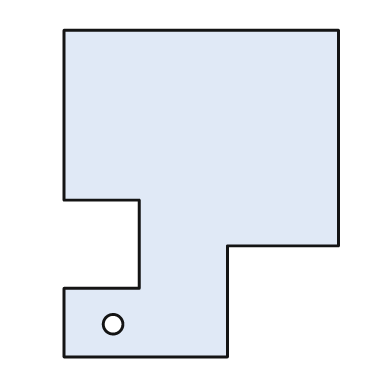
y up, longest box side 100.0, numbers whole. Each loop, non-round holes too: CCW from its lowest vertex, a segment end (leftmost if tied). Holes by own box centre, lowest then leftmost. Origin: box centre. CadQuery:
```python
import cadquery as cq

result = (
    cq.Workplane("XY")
    .moveTo(-42.0, -50.0)
    .lineTo(8.0, -50.0)
    .lineTo(8.0, -16.0)
    .lineTo(42.0, -16.0)
    .lineTo(42.0, 50.0)
    .lineTo(-42.0, 50.0)
    .lineTo(-42.0, -2.0)
    .lineTo(-19.0, -2.0)
    .lineTo(-19.0, -29.0)
    .lineTo(-42.0, -29.0)
    .close()
    .moveTo(-27.0, -40.0)
    .circle(3.0)
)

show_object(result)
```